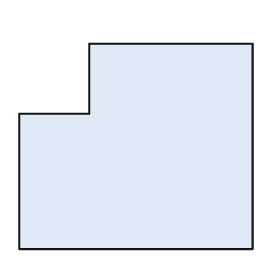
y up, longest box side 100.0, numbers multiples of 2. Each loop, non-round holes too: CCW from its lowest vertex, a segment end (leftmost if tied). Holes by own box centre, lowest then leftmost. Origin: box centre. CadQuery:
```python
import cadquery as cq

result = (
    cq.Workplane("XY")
    .moveTo(-50.0, -44.0)
    .lineTo(50.0, -44.0)
    .lineTo(50.0, 44.0)
    .lineTo(-20.0, 44.0)
    .lineTo(-20.0, 14.0)
    .lineTo(-50.0, 14.0)
    .close()
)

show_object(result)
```